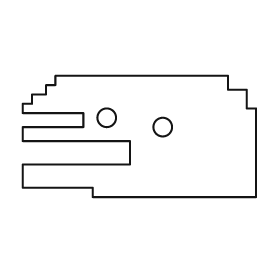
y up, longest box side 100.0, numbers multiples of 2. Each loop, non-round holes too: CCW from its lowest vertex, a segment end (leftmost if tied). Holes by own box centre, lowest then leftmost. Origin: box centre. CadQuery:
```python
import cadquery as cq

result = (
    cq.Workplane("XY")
    .moveTo(-20.0, -26.0)
    .lineTo(50.0, -26.0)
    .lineTo(50.0, 12.0)
    .lineTo(46.0, 12.0)
    .lineTo(46.0, 20.0)
    .lineTo(38.0, 20.0)
    .lineTo(38.0, 26.0)
    .lineTo(-36.0, 26.0)
    .lineTo(-36.0, 22.0)
    .lineTo(-40.0, 22.0)
    .lineTo(-40.0, 18.0)
    .lineTo(-46.0, 18.0)
    .lineTo(-46.0, 14.0)
    .lineTo(-50.0, 14.0)
    .lineTo(-50.0, 10.0)
    .lineTo(-24.0, 10.0)
    .lineTo(-24.0, 4.0)
    .lineTo(-50.0, 4.0)
    .lineTo(-50.0, -2.0)
    .lineTo(-4.0, -2.0)
    .lineTo(-4.0, -12.0)
    .lineTo(-50.0, -12.0)
    .lineTo(-50.0, -22.0)
    .lineTo(-20.0, -22.0)
    .close()
    .moveTo(10.0, 4.0)
    .circle(4.0)
    .moveTo(-14.0, 8.0)
    .circle(4.0)
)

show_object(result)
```